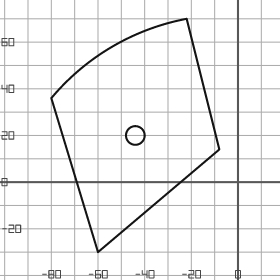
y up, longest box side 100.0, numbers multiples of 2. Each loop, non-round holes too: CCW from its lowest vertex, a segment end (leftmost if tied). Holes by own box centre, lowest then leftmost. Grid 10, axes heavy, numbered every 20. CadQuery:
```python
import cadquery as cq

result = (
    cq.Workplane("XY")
    .moveTo(-60.0, -30.0)
    .lineTo(-8.0, 14.0)
    .lineTo(-22.0, 70.0)
    .threePointArc((-54.0, 58.0), (-80.0, 36.0))
    .close()
    .moveTo(-44.0, 20.0)
    .circle(4.0)
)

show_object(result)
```